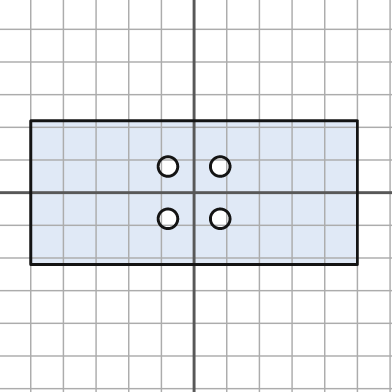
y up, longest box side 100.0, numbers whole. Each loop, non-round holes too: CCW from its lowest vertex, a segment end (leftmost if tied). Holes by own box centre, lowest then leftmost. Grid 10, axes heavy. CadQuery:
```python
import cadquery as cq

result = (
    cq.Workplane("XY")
    .moveTo(-50.0, -22.0)
    .lineTo(50.0, -22.0)
    .lineTo(50.0, 22.0)
    .lineTo(-50.0, 22.0)
    .close()
    .moveTo(-8.0, -8.0)
    .circle(3.0)
    .moveTo(8.0, -8.0)
    .circle(3.0)
    .moveTo(-8.0, 8.0)
    .circle(3.0)
    .moveTo(8.0, 8.0)
    .circle(3.0)
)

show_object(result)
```